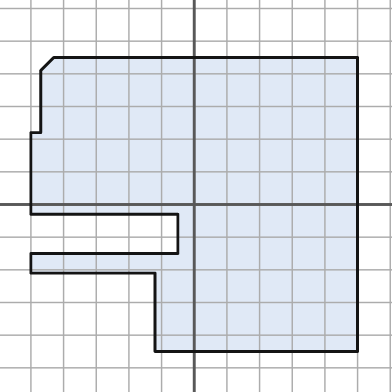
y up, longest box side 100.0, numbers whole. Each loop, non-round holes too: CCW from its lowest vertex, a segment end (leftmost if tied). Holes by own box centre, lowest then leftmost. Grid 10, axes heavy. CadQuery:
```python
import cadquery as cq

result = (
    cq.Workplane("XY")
    .moveTo(-12.0, -45.0)
    .lineTo(50.0, -45.0)
    .lineTo(50.0, 45.0)
    .lineTo(-43.0, 45.0)
    .lineTo(-47.0, 41.0)
    .lineTo(-47.0, 22.0)
    .lineTo(-50.0, 22.0)
    .lineTo(-50.0, -3.0)
    .lineTo(-5.0, -3.0)
    .lineTo(-5.0, -15.0)
    .lineTo(-50.0, -15.0)
    .lineTo(-50.0, -21.0)
    .lineTo(-12.0, -21.0)
    .close()
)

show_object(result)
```